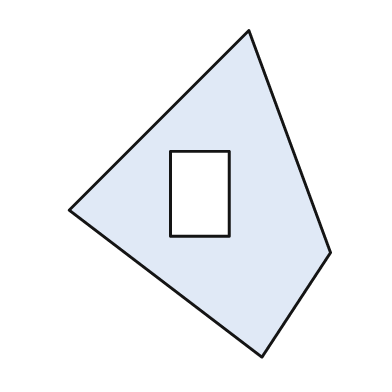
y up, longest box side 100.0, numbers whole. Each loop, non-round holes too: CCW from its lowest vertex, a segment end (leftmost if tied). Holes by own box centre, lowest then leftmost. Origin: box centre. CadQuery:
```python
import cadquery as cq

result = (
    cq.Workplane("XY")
    .moveTo(19.0, -50.0)
    .lineTo(40.0, -18.0)
    .lineTo(15.0, 50.0)
    .lineTo(-40.0, -5.0)
    .close()
    .moveTo(-9.0, -13.0)
    .lineTo(9.0, -13.0)
    .lineTo(9.0, 13.0)
    .lineTo(-9.0, 13.0)
    .close()
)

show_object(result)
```